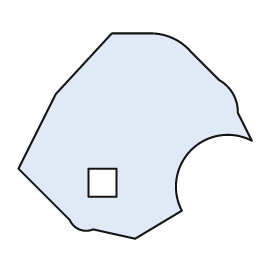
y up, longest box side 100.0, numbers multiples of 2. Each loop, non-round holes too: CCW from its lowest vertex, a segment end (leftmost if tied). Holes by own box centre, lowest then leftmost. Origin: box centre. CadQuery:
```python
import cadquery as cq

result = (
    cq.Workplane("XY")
    .moveTo(0.0, -44.0)
    .lineTo(20.0, -32.0)
    .threePointArc((24.0, -6.0), (50.0, -2.0))
    .lineTo(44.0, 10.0)
    .threePointArc((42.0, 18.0), (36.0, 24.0))
    .lineTo(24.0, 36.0)
    .threePointArc((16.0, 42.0), (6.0, 44.0))
    .lineTo(-10.0, 44.0)
    .lineTo(-34.0, 18.0)
    .lineTo(-50.0, -14.0)
    .lineTo(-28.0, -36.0)
    .threePointArc((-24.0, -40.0), (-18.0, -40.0))
    .close()
    .moveTo(-20.0, -26.0)
    .lineTo(-8.0, -26.0)
    .lineTo(-8.0, -14.0)
    .lineTo(-20.0, -14.0)
    .close()
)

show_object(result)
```